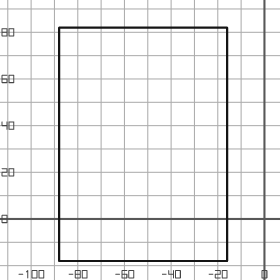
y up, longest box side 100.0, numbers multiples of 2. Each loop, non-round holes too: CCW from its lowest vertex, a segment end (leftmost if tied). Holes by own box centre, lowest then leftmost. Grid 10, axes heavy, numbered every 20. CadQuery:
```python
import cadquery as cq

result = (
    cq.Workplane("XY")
    .moveTo(-88.0, -18.0)
    .lineTo(-16.0, -18.0)
    .lineTo(-16.0, 82.0)
    .lineTo(-88.0, 82.0)
    .close()
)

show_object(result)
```